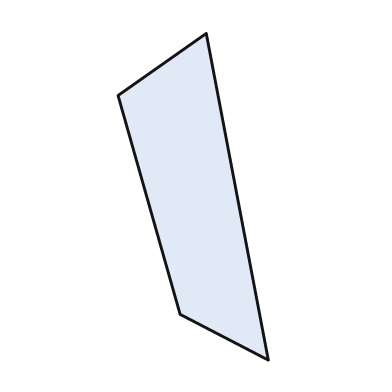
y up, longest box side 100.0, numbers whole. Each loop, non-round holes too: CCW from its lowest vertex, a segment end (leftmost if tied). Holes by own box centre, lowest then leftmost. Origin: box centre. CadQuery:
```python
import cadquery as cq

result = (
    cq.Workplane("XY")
    .moveTo(23.0, -50.0)
    .lineTo(4.0, 50.0)
    .lineTo(-23.0, 31.0)
    .lineTo(-4.0, -36.0)
    .close()
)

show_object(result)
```